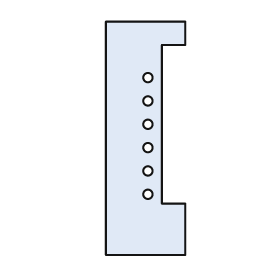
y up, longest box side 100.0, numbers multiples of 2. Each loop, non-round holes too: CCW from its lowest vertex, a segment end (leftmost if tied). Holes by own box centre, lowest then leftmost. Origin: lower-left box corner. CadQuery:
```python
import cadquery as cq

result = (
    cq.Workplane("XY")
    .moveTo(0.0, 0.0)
    .lineTo(34.0, 0.0)
    .lineTo(34.0, 22.0)
    .lineTo(24.0, 22.0)
    .lineTo(24.0, 90.0)
    .lineTo(34.0, 90.0)
    .lineTo(34.0, 100.0)
    .lineTo(0.0, 100.0)
    .close()
    .moveTo(18.0, 26.0)
    .circle(2.0)
    .moveTo(18.0, 36.0)
    .circle(2.0)
    .moveTo(18.0, 46.0)
    .circle(2.0)
    .moveTo(18.0, 56.0)
    .circle(2.0)
    .moveTo(18.0, 66.0)
    .circle(2.0)
    .moveTo(18.0, 76.0)
    .circle(2.0)
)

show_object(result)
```